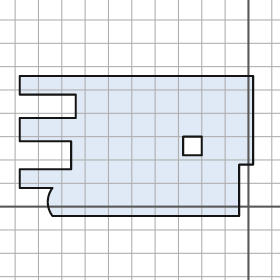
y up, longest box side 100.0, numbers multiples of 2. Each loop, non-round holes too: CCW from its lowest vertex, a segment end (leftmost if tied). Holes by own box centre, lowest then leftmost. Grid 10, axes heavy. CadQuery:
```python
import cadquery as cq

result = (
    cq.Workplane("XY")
    .moveTo(-84.0, -4.0)
    .lineTo(-4.0, -4.0)
    .lineTo(-4.0, 18.0)
    .lineTo(2.0, 18.0)
    .lineTo(2.0, 56.0)
    .lineTo(-98.0, 56.0)
    .lineTo(-98.0, 48.0)
    .lineTo(-74.0, 48.0)
    .lineTo(-74.0, 38.0)
    .lineTo(-98.0, 38.0)
    .lineTo(-98.0, 28.0)
    .lineTo(-76.0, 28.0)
    .lineTo(-76.0, 16.0)
    .lineTo(-98.0, 16.0)
    .lineTo(-98.0, 8.0)
    .lineTo(-84.0, 8.0)
    .threePointArc((-86.0, 2.0), (-84.0, -4.0))
    .close()
    .moveTo(-28.0, 22.0)
    .lineTo(-20.0, 22.0)
    .lineTo(-20.0, 30.0)
    .lineTo(-28.0, 30.0)
    .close()
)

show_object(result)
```